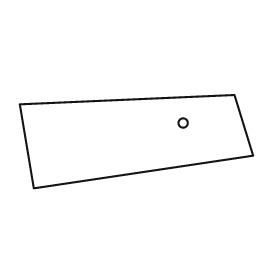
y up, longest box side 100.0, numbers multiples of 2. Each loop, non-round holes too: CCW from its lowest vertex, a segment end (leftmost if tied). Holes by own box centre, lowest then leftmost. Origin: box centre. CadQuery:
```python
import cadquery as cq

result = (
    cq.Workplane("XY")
    .moveTo(-44.0, -20.0)
    .lineTo(50.0, -6.0)
    .lineTo(42.0, 20.0)
    .lineTo(-50.0, 16.0)
    .close()
    .moveTo(20.0, 8.0)
    .circle(2.0)
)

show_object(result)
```